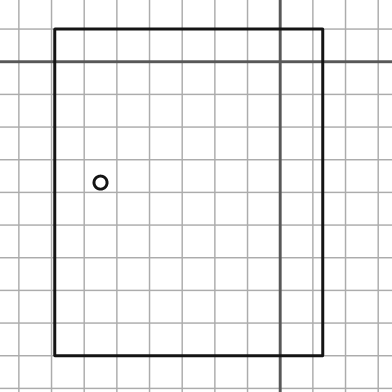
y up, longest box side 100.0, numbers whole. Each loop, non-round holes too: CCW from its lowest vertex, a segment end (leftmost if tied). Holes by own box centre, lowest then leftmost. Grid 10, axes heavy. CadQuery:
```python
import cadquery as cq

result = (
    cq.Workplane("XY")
    .moveTo(-69.0, -90.0)
    .lineTo(13.0, -90.0)
    .lineTo(13.0, 10.0)
    .lineTo(-69.0, 10.0)
    .close()
    .moveTo(-55.0, -37.0)
    .circle(2.0)
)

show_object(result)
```